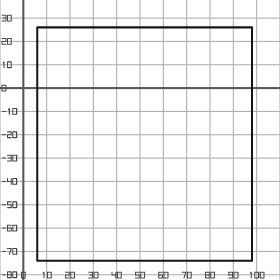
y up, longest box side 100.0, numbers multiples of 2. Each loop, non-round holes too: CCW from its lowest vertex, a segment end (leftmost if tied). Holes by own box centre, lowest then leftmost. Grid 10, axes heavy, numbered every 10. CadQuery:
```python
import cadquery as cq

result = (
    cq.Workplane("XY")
    .moveTo(6.0, -74.0)
    .lineTo(98.0, -74.0)
    .lineTo(98.0, 26.0)
    .lineTo(6.0, 26.0)
    .close()
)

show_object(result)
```